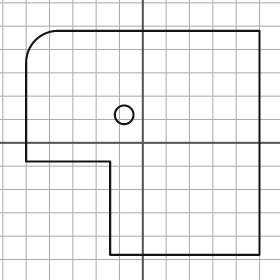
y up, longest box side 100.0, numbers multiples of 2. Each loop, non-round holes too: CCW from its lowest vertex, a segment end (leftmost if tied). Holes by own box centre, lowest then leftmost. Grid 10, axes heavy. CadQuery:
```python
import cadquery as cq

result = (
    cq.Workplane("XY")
    .moveTo(-14.0, -48.0)
    .lineTo(50.0, -48.0)
    .lineTo(50.0, 48.0)
    .lineTo(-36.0, 48.0)
    .threePointArc((-46.0, 44.0), (-50.0, 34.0))
    .lineTo(-50.0, -8.0)
    .lineTo(-14.0, -8.0)
    .close()
    .moveTo(-8.0, 12.0)
    .circle(4.0)
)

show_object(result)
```